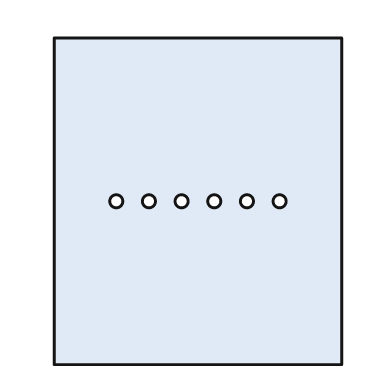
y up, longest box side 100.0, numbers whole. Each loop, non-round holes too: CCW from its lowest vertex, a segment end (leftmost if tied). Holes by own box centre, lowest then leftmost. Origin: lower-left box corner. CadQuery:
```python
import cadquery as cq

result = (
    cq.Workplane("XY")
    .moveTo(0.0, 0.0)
    .lineTo(88.0, 0.0)
    .lineTo(88.0, 100.0)
    .lineTo(0.0, 100.0)
    .close()
    .moveTo(19.0, 50.0)
    .circle(2.0)
    .moveTo(29.0, 50.0)
    .circle(2.0)
    .moveTo(39.0, 50.0)
    .circle(2.0)
    .moveTo(49.0, 50.0)
    .circle(2.0)
    .moveTo(59.0, 50.0)
    .circle(2.0)
    .moveTo(69.0, 50.0)
    .circle(2.0)
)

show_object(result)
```